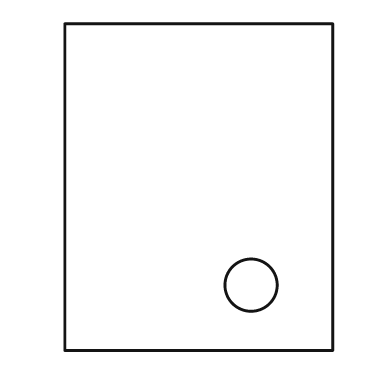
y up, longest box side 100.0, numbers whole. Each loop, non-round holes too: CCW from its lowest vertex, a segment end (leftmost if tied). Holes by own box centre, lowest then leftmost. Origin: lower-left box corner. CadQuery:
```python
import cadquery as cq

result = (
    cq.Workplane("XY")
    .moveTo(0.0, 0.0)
    .lineTo(82.0, 0.0)
    .lineTo(82.0, 100.0)
    .lineTo(0.0, 100.0)
    .close()
    .moveTo(57.0, 20.0)
    .circle(8.0)
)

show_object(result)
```